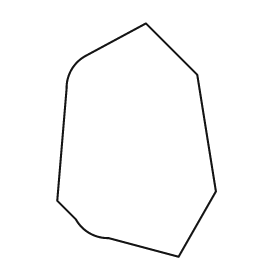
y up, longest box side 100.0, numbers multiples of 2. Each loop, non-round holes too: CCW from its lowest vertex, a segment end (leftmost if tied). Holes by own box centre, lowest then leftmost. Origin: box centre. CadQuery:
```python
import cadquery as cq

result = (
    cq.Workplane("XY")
    .moveTo(18.0, -50.0)
    .lineTo(34.0, -22.0)
    .lineTo(26.0, 28.0)
    .lineTo(4.0, 50.0)
    .lineTo(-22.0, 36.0)
    .threePointArc((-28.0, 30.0), (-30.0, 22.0))
    .lineTo(-34.0, -26.0)
    .lineTo(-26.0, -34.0)
    .threePointArc((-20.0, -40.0), (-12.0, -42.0))
    .close()
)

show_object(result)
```